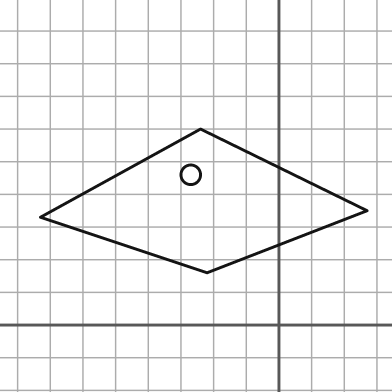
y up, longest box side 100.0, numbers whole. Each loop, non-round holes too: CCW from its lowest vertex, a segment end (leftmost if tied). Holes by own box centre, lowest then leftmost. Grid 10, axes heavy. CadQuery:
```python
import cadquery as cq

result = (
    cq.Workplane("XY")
    .moveTo(-22.0, 16.0)
    .lineTo(27.0, 35.0)
    .lineTo(-24.0, 60.0)
    .lineTo(-73.0, 33.0)
    .close()
    .moveTo(-27.0, 46.0)
    .circle(3.0)
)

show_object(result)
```